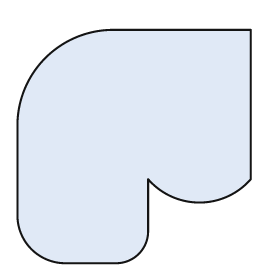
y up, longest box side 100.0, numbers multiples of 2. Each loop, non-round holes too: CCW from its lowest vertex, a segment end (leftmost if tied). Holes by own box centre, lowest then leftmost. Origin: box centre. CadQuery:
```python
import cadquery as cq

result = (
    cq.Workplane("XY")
    .moveTo(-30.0, -50.0)
    .lineTo(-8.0, -50.0)
    .threePointArc((2.0, -46.0), (6.0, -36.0))
    .lineTo(6.0, -14.0)
    .threePointArc((28.0, -24.0), (50.0, -14.0))
    .lineTo(50.0, 50.0)
    .lineTo(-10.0, 50.0)
    .threePointArc((-38.0, 38.0), (-50.0, 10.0))
    .lineTo(-50.0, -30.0)
    .threePointArc((-44.0, -44.0), (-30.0, -50.0))
    .close()
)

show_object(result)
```